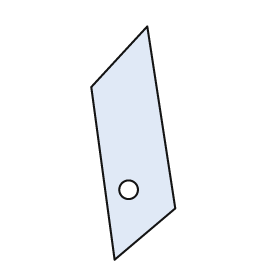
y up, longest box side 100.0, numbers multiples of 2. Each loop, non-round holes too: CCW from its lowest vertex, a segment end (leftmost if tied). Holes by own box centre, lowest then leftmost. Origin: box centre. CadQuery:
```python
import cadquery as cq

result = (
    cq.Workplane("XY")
    .moveTo(-8.0, -50.0)
    .lineTo(18.0, -28.0)
    .lineTo(6.0, 50.0)
    .lineTo(-18.0, 24.0)
    .close()
    .moveTo(-2.0, -20.0)
    .circle(4.0)
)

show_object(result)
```